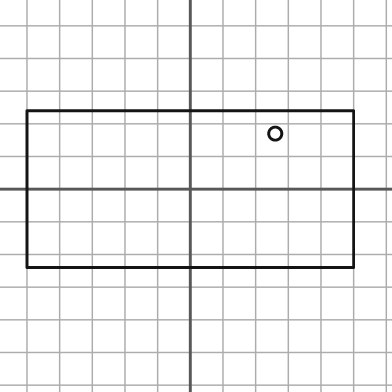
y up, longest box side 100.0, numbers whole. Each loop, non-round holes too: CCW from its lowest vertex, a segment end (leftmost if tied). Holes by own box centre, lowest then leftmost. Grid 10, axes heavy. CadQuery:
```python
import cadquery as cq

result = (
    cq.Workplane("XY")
    .moveTo(-50.0, -24.0)
    .lineTo(50.0, -24.0)
    .lineTo(50.0, 24.0)
    .lineTo(-50.0, 24.0)
    .close()
    .moveTo(26.0, 17.0)
    .circle(2.0)
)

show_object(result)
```